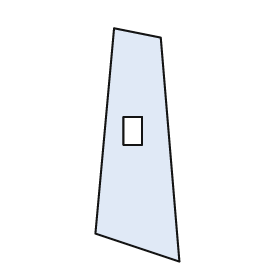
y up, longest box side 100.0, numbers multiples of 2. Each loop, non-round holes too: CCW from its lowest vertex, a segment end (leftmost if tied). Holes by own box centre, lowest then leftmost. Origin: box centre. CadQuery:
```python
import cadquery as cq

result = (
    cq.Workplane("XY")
    .moveTo(18.0, -50.0)
    .lineTo(10.0, 46.0)
    .lineTo(-10.0, 50.0)
    .lineTo(-18.0, -38.0)
    .close()
    .moveTo(-6.0, 0.0)
    .lineTo(2.0, 0.0)
    .lineTo(2.0, 12.0)
    .lineTo(-6.0, 12.0)
    .close()
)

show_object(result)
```